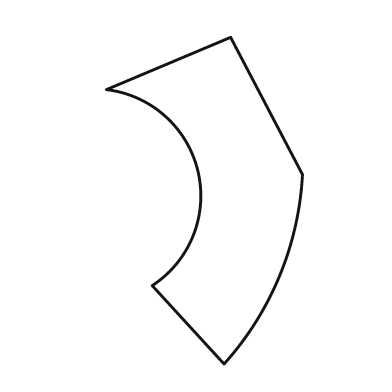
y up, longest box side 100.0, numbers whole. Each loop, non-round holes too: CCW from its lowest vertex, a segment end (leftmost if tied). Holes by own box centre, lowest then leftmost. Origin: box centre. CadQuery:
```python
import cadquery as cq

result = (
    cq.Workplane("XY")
    .moveTo(6.0, -50.0)
    .threePointArc((23.0, -23.0), (30.0, 8.0))
    .lineTo(8.0, 50.0)
    .lineTo(-30.0, 34.0)
    .threePointArc((-2.0, 9.0), (-16.0, -26.0))
    .close()
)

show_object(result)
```